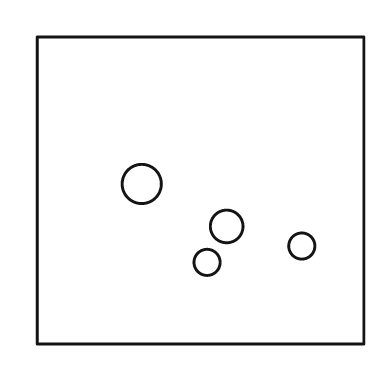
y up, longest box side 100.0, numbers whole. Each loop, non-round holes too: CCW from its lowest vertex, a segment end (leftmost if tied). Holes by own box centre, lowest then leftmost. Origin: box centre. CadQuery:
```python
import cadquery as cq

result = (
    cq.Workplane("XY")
    .moveTo(-50.0, -47.0)
    .lineTo(50.0, -47.0)
    .lineTo(50.0, 47.0)
    .lineTo(-50.0, 47.0)
    .close()
    .moveTo(2.0, -22.0)
    .circle(4.0)
    .moveTo(31.0, -17.0)
    .circle(4.0)
    .moveTo(8.0, -11.0)
    .circle(5.0)
    .moveTo(-18.0, 2.0)
    .circle(6.0)
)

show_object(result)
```